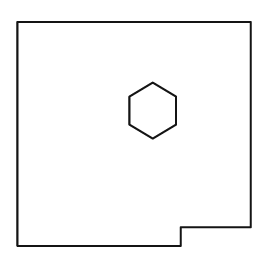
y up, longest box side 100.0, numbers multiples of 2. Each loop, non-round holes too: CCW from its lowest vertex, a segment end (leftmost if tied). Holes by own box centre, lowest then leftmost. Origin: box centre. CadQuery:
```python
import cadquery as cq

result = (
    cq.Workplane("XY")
    .moveTo(-50.0, -48.0)
    .lineTo(20.0, -48.0)
    .lineTo(20.0, -40.0)
    .lineTo(50.0, -40.0)
    .lineTo(50.0, 48.0)
    .lineTo(-50.0, 48.0)
    .close()
    .moveTo(8.0, -2.0)
    .lineTo(18.0, 4.0)
    .lineTo(18.0, 16.0)
    .lineTo(8.0, 22.0)
    .lineTo(-2.0, 16.0)
    .lineTo(-2.0, 4.0)
    .close()
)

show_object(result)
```